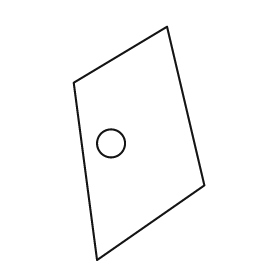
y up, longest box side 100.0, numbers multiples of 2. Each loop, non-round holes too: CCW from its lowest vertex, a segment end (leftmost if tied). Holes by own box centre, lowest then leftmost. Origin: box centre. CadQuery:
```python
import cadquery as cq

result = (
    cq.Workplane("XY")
    .moveTo(-18.0, -50.0)
    .lineTo(28.0, -18.0)
    .lineTo(12.0, 50.0)
    .lineTo(-28.0, 26.0)
    .close()
    .moveTo(-12.0, 0.0)
    .circle(6.0)
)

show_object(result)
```